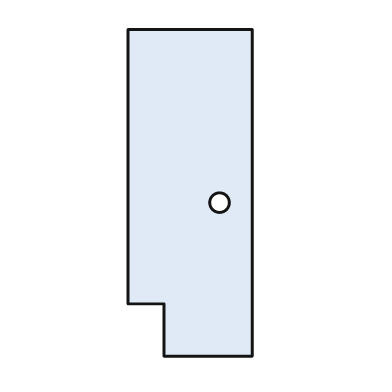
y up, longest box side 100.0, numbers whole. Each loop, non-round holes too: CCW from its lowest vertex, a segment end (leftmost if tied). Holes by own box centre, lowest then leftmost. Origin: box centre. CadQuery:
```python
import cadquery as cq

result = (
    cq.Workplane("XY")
    .moveTo(-8.0, -50.0)
    .lineTo(19.0, -50.0)
    .lineTo(19.0, 50.0)
    .lineTo(-19.0, 50.0)
    .lineTo(-19.0, -34.0)
    .lineTo(-8.0, -34.0)
    .close()
    .moveTo(9.0, -3.0)
    .circle(3.0)
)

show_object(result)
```